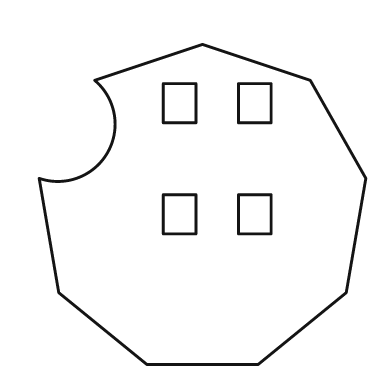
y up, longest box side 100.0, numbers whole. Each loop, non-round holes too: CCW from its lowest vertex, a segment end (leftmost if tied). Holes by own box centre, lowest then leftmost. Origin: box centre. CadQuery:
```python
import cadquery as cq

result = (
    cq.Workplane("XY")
    .moveTo(-17.0, -49.0)
    .lineTo(17.0, -49.0)
    .lineTo(44.0, -27.0)
    .lineTo(50.0, 8.0)
    .lineTo(33.0, 38.0)
    .lineTo(0.0, 49.0)
    .lineTo(-33.0, 38.0)
    .threePointArc((-29.0, 16.0), (-50.0, 8.0))
    .lineTo(-44.0, -27.0)
    .close()
    .moveTo(-12.0, -9.0)
    .lineTo(-2.0, -9.0)
    .lineTo(-2.0, 3.0)
    .lineTo(-12.0, 3.0)
    .close()
    .moveTo(11.0, -9.0)
    .lineTo(21.0, -9.0)
    .lineTo(21.0, 3.0)
    .lineTo(11.0, 3.0)
    .close()
    .moveTo(-12.0, 25.0)
    .lineTo(-2.0, 25.0)
    .lineTo(-2.0, 37.0)
    .lineTo(-12.0, 37.0)
    .close()
    .moveTo(11.0, 25.0)
    .lineTo(21.0, 25.0)
    .lineTo(21.0, 37.0)
    .lineTo(11.0, 37.0)
    .close()
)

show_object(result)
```